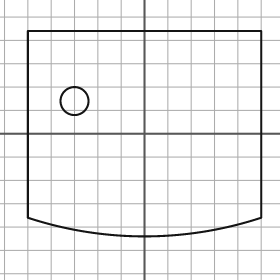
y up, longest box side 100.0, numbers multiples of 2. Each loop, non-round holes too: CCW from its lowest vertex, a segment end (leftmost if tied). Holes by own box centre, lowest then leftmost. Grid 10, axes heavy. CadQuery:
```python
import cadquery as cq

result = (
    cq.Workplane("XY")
    .moveTo(-50.0, -36.0)
    .threePointArc((0.0, -44.0), (50.0, -36.0))
    .lineTo(50.0, 44.0)
    .lineTo(-50.0, 44.0)
    .close()
    .moveTo(-30.0, 14.0)
    .circle(6.0)
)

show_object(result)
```